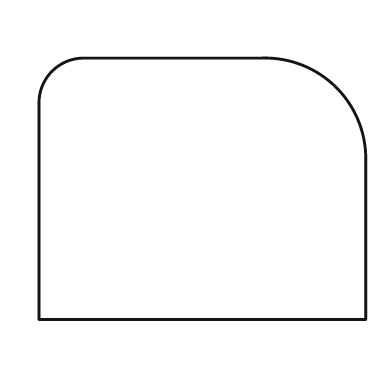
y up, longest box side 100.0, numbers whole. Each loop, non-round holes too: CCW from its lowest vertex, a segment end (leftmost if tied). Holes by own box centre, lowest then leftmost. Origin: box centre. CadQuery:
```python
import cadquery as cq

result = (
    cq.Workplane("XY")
    .moveTo(-50.0, -40.0)
    .lineTo(50.0, -40.0)
    .lineTo(50.0, 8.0)
    .threePointArc((41.0, 31.0), (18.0, 40.0))
    .lineTo(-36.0, 40.0)
    .threePointArc((-46.0, 36.0), (-50.0, 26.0))
    .close()
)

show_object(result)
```